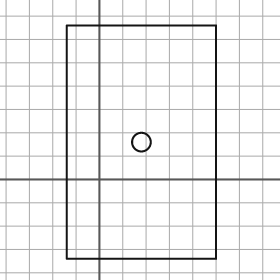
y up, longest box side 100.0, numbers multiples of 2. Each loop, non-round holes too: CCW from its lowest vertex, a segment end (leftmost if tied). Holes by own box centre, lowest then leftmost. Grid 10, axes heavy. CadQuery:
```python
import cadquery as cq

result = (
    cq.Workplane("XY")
    .moveTo(-14.0, -34.0)
    .lineTo(50.0, -34.0)
    .lineTo(50.0, 66.0)
    .lineTo(-14.0, 66.0)
    .close()
    .moveTo(18.0, 16.0)
    .circle(4.0)
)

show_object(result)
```